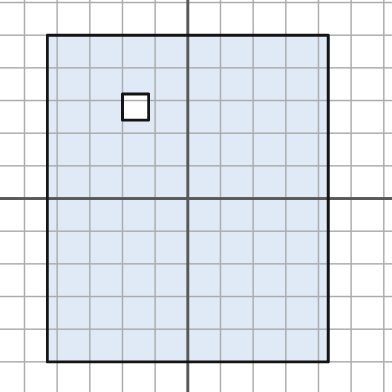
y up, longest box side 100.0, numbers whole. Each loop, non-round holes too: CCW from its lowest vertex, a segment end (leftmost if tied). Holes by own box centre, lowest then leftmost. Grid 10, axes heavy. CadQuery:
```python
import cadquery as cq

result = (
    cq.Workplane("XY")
    .moveTo(-43.0, -50.0)
    .lineTo(43.0, -50.0)
    .lineTo(43.0, 50.0)
    .lineTo(-43.0, 50.0)
    .close()
    .moveTo(-20.0, 24.0)
    .lineTo(-12.0, 24.0)
    .lineTo(-12.0, 32.0)
    .lineTo(-20.0, 32.0)
    .close()
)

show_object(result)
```